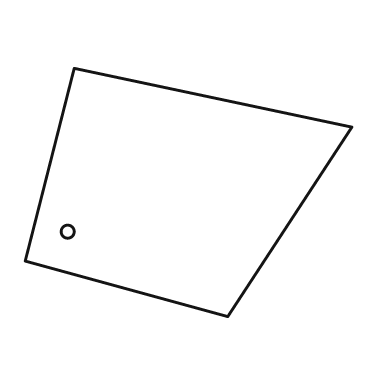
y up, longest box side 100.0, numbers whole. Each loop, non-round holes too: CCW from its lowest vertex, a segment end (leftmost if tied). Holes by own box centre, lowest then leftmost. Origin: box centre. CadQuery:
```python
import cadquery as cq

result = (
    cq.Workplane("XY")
    .moveTo(12.0, -38.0)
    .lineTo(50.0, 20.0)
    .lineTo(-35.0, 38.0)
    .lineTo(-50.0, -21.0)
    .close()
    .moveTo(-37.0, -12.0)
    .circle(2.0)
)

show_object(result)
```